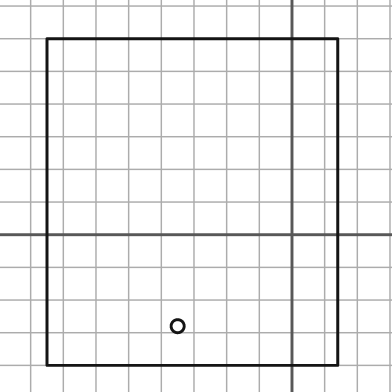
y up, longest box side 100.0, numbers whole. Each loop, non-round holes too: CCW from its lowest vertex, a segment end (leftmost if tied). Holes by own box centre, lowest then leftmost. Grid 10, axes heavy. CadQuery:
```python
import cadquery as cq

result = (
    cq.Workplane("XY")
    .moveTo(-75.0, -40.0)
    .lineTo(14.0, -40.0)
    .lineTo(14.0, 60.0)
    .lineTo(-75.0, 60.0)
    .close()
    .moveTo(-35.0, -28.0)
    .circle(2.0)
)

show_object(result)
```